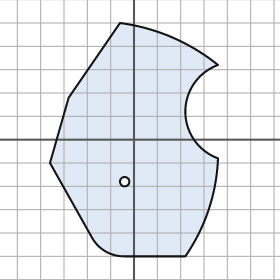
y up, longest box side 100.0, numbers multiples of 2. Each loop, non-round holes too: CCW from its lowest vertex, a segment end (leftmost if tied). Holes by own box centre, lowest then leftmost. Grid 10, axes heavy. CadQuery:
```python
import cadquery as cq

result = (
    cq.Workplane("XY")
    .moveTo(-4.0, -50.0)
    .lineTo(22.0, -50.0)
    .threePointArc((32.0, -30.0), (36.0, -8.0))
    .threePointArc((22.0, 12.0), (36.0, 32.0))
    .threePointArc((16.0, 44.0), (-6.0, 50.0))
    .lineTo(-28.0, 18.0)
    .lineTo(-36.0, -10.0)
    .lineTo(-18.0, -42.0)
    .threePointArc((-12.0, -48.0), (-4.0, -50.0))
    .close()
    .moveTo(-4.0, -18.0)
    .circle(2.0)
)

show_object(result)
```